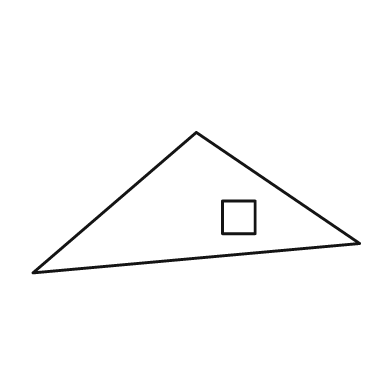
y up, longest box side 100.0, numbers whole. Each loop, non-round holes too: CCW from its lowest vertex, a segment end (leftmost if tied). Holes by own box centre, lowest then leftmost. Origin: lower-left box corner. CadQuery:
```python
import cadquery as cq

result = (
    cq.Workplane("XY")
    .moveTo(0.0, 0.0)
    .lineTo(100.0, 9.0)
    .lineTo(50.0, 43.0)
    .close()
    .moveTo(58.0, 12.0)
    .lineTo(68.0, 12.0)
    .lineTo(68.0, 22.0)
    .lineTo(58.0, 22.0)
    .close()
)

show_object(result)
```